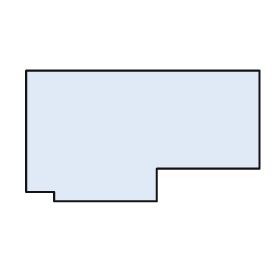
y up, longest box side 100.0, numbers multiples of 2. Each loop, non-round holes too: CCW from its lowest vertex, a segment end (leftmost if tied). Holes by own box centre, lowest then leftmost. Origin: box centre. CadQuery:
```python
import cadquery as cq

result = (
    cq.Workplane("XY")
    .moveTo(-38.0, -28.0)
    .lineTo(6.0, -28.0)
    .lineTo(6.0, -14.0)
    .lineTo(50.0, -14.0)
    .lineTo(50.0, 28.0)
    .lineTo(-50.0, 28.0)
    .lineTo(-50.0, -24.0)
    .lineTo(-38.0, -24.0)
    .close()
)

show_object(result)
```